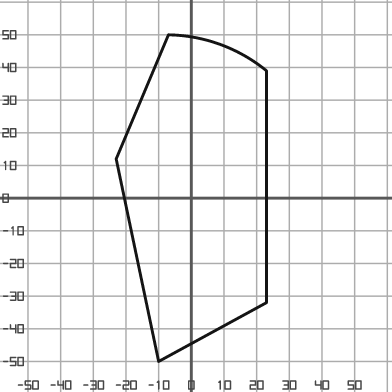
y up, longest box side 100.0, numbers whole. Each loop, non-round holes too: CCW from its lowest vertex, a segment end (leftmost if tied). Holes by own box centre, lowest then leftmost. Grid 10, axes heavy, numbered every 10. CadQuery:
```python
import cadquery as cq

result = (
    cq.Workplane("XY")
    .moveTo(-10.0, -50.0)
    .lineTo(23.0, -32.0)
    .lineTo(23.0, 39.0)
    .threePointArc((9.0, 47.0), (-7.0, 50.0))
    .lineTo(-23.0, 12.0)
    .close()
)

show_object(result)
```